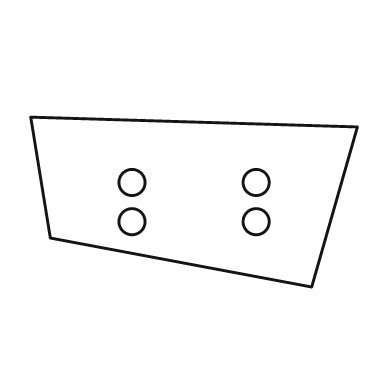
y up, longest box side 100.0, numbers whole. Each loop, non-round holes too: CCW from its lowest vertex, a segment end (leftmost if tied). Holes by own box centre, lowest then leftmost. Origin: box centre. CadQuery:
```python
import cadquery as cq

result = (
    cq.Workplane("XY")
    .moveTo(36.0, -26.0)
    .lineTo(50.0, 23.0)
    .lineTo(-50.0, 26.0)
    .lineTo(-44.0, -11.0)
    .close()
    .moveTo(-19.0, -6.0)
    .circle(4.0)
    .moveTo(19.0, -6.0)
    .circle(4.0)
    .moveTo(-19.0, 6.0)
    .circle(4.0)
    .moveTo(19.0, 6.0)
    .circle(4.0)
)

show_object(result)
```